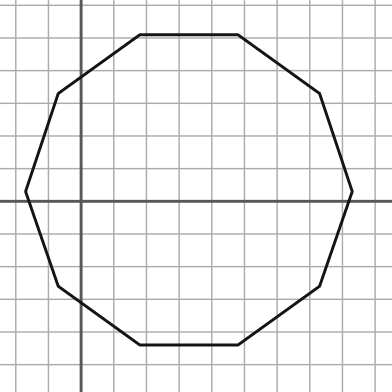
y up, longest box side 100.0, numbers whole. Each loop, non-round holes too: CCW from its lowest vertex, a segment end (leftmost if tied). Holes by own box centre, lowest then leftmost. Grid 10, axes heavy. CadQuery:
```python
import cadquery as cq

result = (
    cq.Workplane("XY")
    .moveTo(18.0, -44.0)
    .lineTo(48.0, -44.0)
    .lineTo(73.0, -26.0)
    .lineTo(83.0, 3.0)
    .lineTo(73.0, 33.0)
    .lineTo(48.0, 51.0)
    .lineTo(18.0, 51.0)
    .lineTo(-7.0, 33.0)
    .lineTo(-17.0, 3.0)
    .lineTo(-7.0, -26.0)
    .close()
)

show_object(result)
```